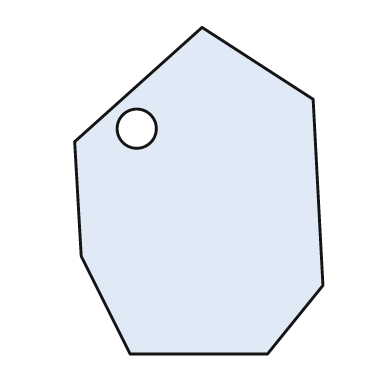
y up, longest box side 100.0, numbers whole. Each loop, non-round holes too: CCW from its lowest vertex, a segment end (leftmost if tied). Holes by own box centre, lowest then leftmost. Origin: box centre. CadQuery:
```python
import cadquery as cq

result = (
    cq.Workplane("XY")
    .moveTo(-21.0, -50.0)
    .lineTo(21.0, -50.0)
    .lineTo(38.0, -29.0)
    .lineTo(35.0, 28.0)
    .lineTo(1.0, 50.0)
    .lineTo(-38.0, 15.0)
    .lineTo(-36.0, -20.0)
    .close()
    .moveTo(-19.0, 19.0)
    .circle(6.0)
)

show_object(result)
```